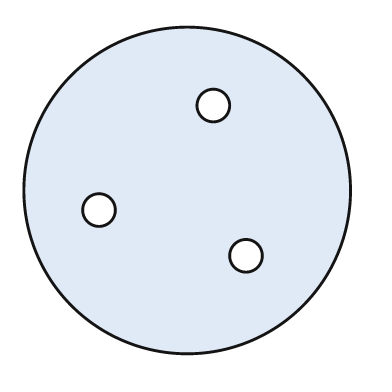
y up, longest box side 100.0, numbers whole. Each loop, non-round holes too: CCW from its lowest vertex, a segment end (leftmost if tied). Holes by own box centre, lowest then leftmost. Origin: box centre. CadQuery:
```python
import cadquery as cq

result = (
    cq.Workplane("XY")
    .moveTo(0.0, 0.0)
    .circle(50.0)
    .moveTo(18.0, -20.0)
    .circle(5.0)
    .moveTo(-27.0, -6.0)
    .circle(5.0)
    .moveTo(8.0, 26.0)
    .circle(5.0)
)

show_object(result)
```